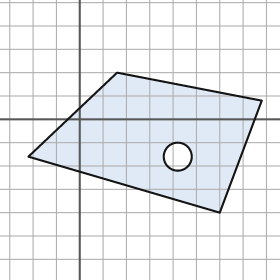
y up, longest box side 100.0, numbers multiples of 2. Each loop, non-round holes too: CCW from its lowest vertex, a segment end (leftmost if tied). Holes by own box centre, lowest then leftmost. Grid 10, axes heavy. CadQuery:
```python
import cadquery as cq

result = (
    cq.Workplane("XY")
    .moveTo(60.0, -40.0)
    .lineTo(78.0, 8.0)
    .lineTo(16.0, 20.0)
    .lineTo(-22.0, -16.0)
    .close()
    .moveTo(42.0, -16.0)
    .circle(6.0)
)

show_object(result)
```